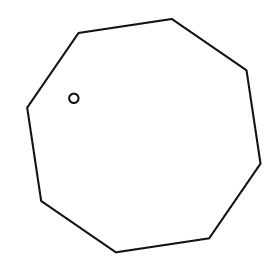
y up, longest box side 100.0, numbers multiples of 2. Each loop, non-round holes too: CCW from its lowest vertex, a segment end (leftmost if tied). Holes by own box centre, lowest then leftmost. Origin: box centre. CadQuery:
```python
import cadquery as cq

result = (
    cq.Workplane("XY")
    .moveTo(-12.0, -50.0)
    .lineTo(28.0, -44.0)
    .lineTo(50.0, -12.0)
    .lineTo(44.0, 28.0)
    .lineTo(12.0, 50.0)
    .lineTo(-28.0, 44.0)
    .lineTo(-50.0, 12.0)
    .lineTo(-44.0, -28.0)
    .close()
    .moveTo(-30.0, 16.0)
    .circle(2.0)
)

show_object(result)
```